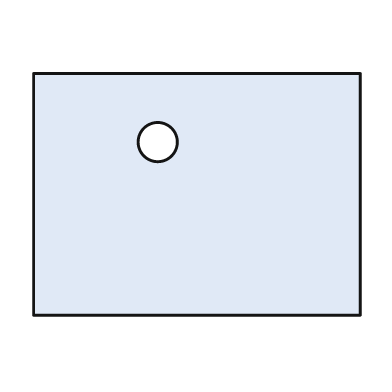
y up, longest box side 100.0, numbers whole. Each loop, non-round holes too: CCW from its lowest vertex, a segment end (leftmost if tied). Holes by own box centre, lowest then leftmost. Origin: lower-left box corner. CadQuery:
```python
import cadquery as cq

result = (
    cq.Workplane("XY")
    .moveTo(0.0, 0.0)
    .lineTo(100.0, 0.0)
    .lineTo(100.0, 74.0)
    .lineTo(0.0, 74.0)
    .close()
    .moveTo(38.0, 53.0)
    .circle(6.0)
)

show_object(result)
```